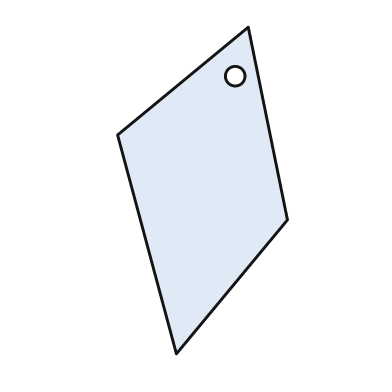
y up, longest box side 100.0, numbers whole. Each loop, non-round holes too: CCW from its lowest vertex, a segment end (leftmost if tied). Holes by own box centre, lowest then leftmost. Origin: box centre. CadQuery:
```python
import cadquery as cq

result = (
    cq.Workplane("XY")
    .moveTo(-8.0, -50.0)
    .lineTo(26.0, -9.0)
    .lineTo(14.0, 50.0)
    .lineTo(-26.0, 17.0)
    .close()
    .moveTo(10.0, 35.0)
    .circle(3.0)
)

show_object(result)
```